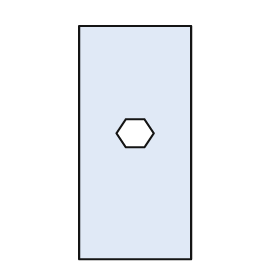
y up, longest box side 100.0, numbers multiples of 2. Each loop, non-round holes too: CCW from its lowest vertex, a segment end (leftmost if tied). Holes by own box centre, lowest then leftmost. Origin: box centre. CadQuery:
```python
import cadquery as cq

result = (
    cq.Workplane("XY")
    .moveTo(-24.0, -50.0)
    .lineTo(24.0, -50.0)
    .lineTo(24.0, 50.0)
    .lineTo(-24.0, 50.0)
    .close()
    .moveTo(-4.0, -2.0)
    .lineTo(4.0, -2.0)
    .lineTo(8.0, 4.0)
    .lineTo(4.0, 10.0)
    .lineTo(-4.0, 10.0)
    .lineTo(-8.0, 4.0)
    .close()
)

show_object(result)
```